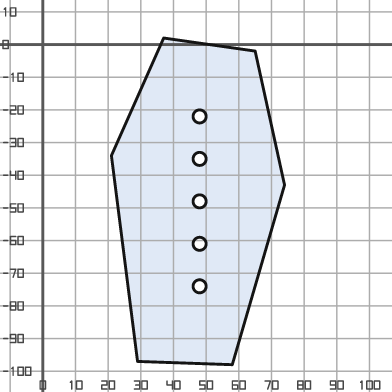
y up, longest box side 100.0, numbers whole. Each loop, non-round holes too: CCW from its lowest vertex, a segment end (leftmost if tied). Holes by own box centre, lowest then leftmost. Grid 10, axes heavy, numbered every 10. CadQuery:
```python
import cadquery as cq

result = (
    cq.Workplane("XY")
    .moveTo(58.0, -98.0)
    .lineTo(74.0, -43.0)
    .lineTo(65.0, -2.0)
    .lineTo(37.0, 2.0)
    .lineTo(21.0, -34.0)
    .lineTo(29.0, -97.0)
    .close()
    .moveTo(48.0, -74.0)
    .circle(2.0)
    .moveTo(48.0, -61.0)
    .circle(2.0)
    .moveTo(48.0, -48.0)
    .circle(2.0)
    .moveTo(48.0, -35.0)
    .circle(2.0)
    .moveTo(48.0, -22.0)
    .circle(2.0)
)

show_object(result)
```